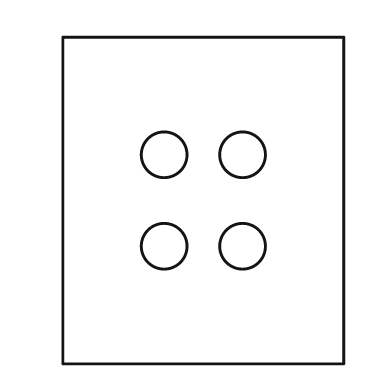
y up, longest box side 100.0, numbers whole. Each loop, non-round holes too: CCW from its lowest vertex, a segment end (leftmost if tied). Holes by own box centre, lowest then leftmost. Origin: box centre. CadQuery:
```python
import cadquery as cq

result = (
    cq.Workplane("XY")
    .moveTo(-43.0, -50.0)
    .lineTo(43.0, -50.0)
    .lineTo(43.0, 50.0)
    .lineTo(-43.0, 50.0)
    .close()
    .moveTo(-12.0, -14.0)
    .circle(7.0)
    .moveTo(12.0, -14.0)
    .circle(7.0)
    .moveTo(-12.0, 14.0)
    .circle(7.0)
    .moveTo(12.0, 14.0)
    .circle(7.0)
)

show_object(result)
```